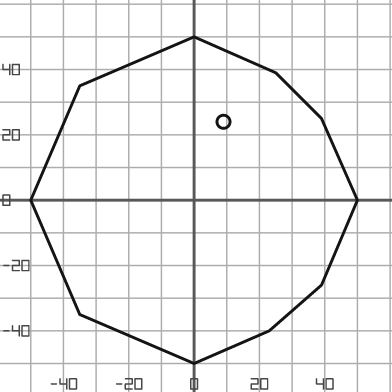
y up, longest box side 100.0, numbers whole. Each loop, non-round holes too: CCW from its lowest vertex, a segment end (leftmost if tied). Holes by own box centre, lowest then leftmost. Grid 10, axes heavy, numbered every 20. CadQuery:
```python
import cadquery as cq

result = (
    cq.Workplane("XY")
    .moveTo(0.0, -50.0)
    .lineTo(23.0, -40.0)
    .lineTo(39.0, -26.0)
    .lineTo(50.0, 0.0)
    .lineTo(39.0, 25.0)
    .lineTo(25.0, 39.0)
    .lineTo(0.0, 50.0)
    .lineTo(-35.0, 35.0)
    .lineTo(-50.0, 0.0)
    .lineTo(-35.0, -35.0)
    .close()
    .moveTo(9.0, 24.0)
    .circle(2.0)
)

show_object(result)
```